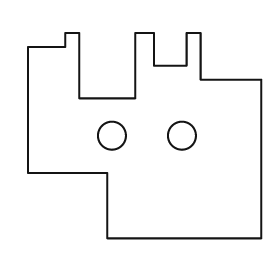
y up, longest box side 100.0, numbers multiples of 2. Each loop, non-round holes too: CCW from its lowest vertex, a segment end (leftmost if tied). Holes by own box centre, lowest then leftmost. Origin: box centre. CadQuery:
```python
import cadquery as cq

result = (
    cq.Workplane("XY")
    .moveTo(-16.0, -44.0)
    .lineTo(50.0, -44.0)
    .lineTo(50.0, 24.0)
    .lineTo(24.0, 24.0)
    .lineTo(24.0, 44.0)
    .lineTo(18.0, 44.0)
    .lineTo(18.0, 30.0)
    .lineTo(4.0, 30.0)
    .lineTo(4.0, 44.0)
    .lineTo(-4.0, 44.0)
    .lineTo(-4.0, 16.0)
    .lineTo(-28.0, 16.0)
    .lineTo(-28.0, 44.0)
    .lineTo(-34.0, 44.0)
    .lineTo(-34.0, 38.0)
    .lineTo(-50.0, 38.0)
    .lineTo(-50.0, -16.0)
    .lineTo(-16.0, -16.0)
    .close()
    .moveTo(-14.0, 0.0)
    .circle(6.0)
    .moveTo(16.0, 0.0)
    .circle(6.0)
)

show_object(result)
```